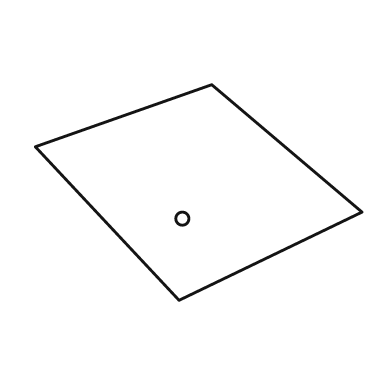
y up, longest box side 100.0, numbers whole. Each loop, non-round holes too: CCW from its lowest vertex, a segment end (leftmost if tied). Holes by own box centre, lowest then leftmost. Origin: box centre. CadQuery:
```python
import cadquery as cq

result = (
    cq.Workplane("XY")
    .moveTo(-6.0, -33.0)
    .lineTo(50.0, -6.0)
    .lineTo(4.0, 33.0)
    .lineTo(-50.0, 14.0)
    .close()
    .moveTo(-5.0, -8.0)
    .circle(2.0)
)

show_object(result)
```